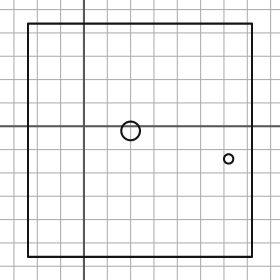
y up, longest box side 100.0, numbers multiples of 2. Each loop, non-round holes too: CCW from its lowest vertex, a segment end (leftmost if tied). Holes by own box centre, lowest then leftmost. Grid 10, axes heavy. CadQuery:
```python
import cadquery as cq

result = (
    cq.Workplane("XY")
    .moveTo(-24.0, -56.0)
    .lineTo(72.0, -56.0)
    .lineTo(72.0, 44.0)
    .lineTo(-24.0, 44.0)
    .close()
    .moveTo(62.0, -14.0)
    .circle(2.0)
    .moveTo(20.0, -2.0)
    .circle(4.0)
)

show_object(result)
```